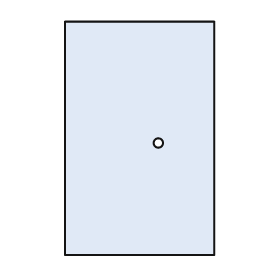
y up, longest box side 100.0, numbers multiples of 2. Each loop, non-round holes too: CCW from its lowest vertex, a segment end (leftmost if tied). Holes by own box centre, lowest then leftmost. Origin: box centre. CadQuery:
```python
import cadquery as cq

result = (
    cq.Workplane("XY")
    .moveTo(-32.0, -50.0)
    .lineTo(32.0, -50.0)
    .lineTo(32.0, 50.0)
    .lineTo(-32.0, 50.0)
    .close()
    .moveTo(8.0, -2.0)
    .circle(2.0)
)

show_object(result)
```